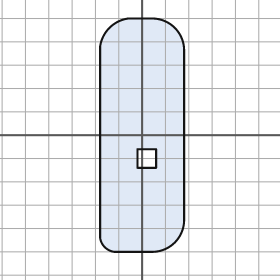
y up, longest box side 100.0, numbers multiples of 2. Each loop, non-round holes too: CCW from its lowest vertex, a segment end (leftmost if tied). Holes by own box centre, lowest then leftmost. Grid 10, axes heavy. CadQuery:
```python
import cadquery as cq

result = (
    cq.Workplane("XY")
    .moveTo(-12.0, -50.0)
    .lineTo(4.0, -50.0)
    .threePointArc((14.0, -46.0), (18.0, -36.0))
    .lineTo(18.0, 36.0)
    .threePointArc((14.0, 46.0), (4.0, 50.0))
    .lineTo(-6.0, 50.0)
    .threePointArc((-14.0, 46.0), (-18.0, 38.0))
    .lineTo(-18.0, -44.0)
    .threePointArc((-16.0, -48.0), (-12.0, -50.0))
    .close()
    .moveTo(-2.0, -14.0)
    .lineTo(6.0, -14.0)
    .lineTo(6.0, -6.0)
    .lineTo(-2.0, -6.0)
    .close()
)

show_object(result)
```